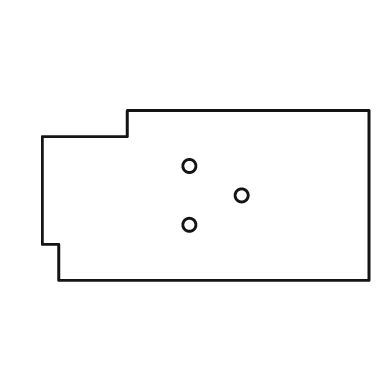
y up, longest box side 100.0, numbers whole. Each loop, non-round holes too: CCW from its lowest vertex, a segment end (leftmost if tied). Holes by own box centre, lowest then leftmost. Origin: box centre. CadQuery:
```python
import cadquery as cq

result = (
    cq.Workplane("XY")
    .moveTo(-45.0, -26.0)
    .lineTo(50.0, -26.0)
    .lineTo(50.0, 26.0)
    .lineTo(-24.0, 26.0)
    .lineTo(-24.0, 18.0)
    .lineTo(-50.0, 18.0)
    .lineTo(-50.0, -15.0)
    .lineTo(-45.0, -15.0)
    .close()
    .moveTo(-5.0, -9.0)
    .circle(2.0)
    .moveTo(11.0, 0.0)
    .circle(2.0)
    .moveTo(-5.0, 9.0)
    .circle(2.0)
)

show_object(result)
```